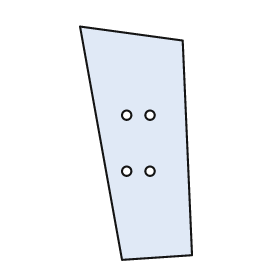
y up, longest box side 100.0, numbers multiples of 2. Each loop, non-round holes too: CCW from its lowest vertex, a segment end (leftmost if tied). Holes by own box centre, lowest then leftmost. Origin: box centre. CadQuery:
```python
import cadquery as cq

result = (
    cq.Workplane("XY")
    .moveTo(-6.0, -50.0)
    .lineTo(24.0, -48.0)
    .lineTo(20.0, 44.0)
    .lineTo(-24.0, 50.0)
    .close()
    .moveTo(-4.0, -12.0)
    .circle(2.0)
    .moveTo(6.0, -12.0)
    .circle(2.0)
    .moveTo(-4.0, 12.0)
    .circle(2.0)
    .moveTo(6.0, 12.0)
    .circle(2.0)
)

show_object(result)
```